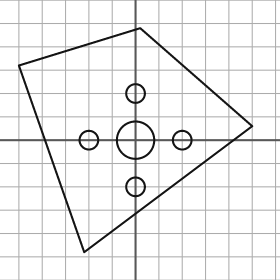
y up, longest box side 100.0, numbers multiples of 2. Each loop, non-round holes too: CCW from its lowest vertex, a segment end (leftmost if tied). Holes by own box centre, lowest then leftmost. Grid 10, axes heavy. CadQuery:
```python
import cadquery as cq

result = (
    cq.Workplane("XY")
    .moveTo(-22.0, -48.0)
    .lineTo(50.0, 6.0)
    .lineTo(2.0, 48.0)
    .lineTo(-50.0, 32.0)
    .close()
    .moveTo(0.0, -20.0)
    .circle(4.0)
    .moveTo(-20.0, 0.0)
    .circle(4.0)
    .moveTo(0.0, 0.0)
    .circle(8.0)
    .moveTo(20.0, 0.0)
    .circle(4.0)
    .moveTo(0.0, 20.0)
    .circle(4.0)
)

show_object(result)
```